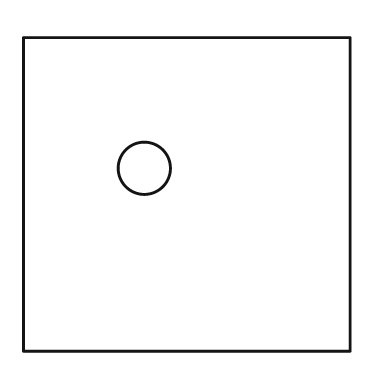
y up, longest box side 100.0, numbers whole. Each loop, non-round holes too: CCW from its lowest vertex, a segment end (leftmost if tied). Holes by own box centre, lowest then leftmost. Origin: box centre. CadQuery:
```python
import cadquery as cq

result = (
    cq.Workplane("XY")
    .moveTo(-50.0, -48.0)
    .lineTo(50.0, -48.0)
    .lineTo(50.0, 48.0)
    .lineTo(-50.0, 48.0)
    .close()
    .moveTo(-13.0, 8.0)
    .circle(8.0)
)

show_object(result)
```